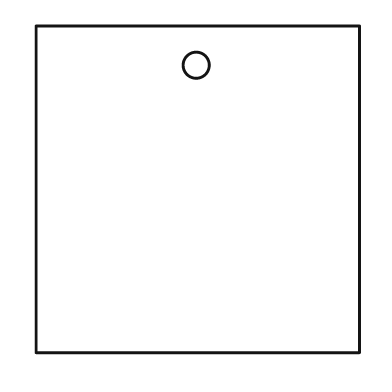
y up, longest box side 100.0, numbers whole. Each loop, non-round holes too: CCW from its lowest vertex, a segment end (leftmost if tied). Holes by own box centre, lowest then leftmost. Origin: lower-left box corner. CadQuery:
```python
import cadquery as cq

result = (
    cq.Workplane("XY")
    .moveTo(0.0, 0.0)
    .lineTo(99.0, 0.0)
    .lineTo(99.0, 100.0)
    .lineTo(0.0, 100.0)
    .close()
    .moveTo(49.0, 88.0)
    .circle(4.0)
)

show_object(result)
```